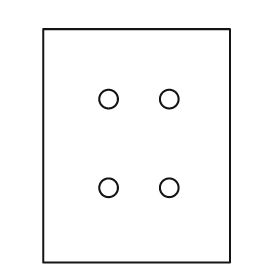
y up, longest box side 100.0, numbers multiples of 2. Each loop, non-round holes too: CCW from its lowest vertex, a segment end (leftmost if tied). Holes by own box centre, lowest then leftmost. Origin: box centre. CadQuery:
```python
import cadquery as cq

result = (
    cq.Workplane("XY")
    .moveTo(-40.0, -50.0)
    .lineTo(40.0, -50.0)
    .lineTo(40.0, 50.0)
    .lineTo(-40.0, 50.0)
    .close()
    .moveTo(-12.0, -18.0)
    .circle(4.0)
    .moveTo(14.0, -18.0)
    .circle(4.0)
    .moveTo(-12.0, 20.0)
    .circle(4.0)
    .moveTo(14.0, 20.0)
    .circle(4.0)
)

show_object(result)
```